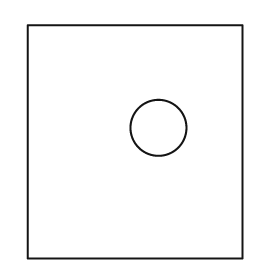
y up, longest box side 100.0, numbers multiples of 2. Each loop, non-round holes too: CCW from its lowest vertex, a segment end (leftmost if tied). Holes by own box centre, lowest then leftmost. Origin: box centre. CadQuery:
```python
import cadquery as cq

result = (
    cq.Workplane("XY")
    .moveTo(-46.0, -50.0)
    .lineTo(46.0, -50.0)
    .lineTo(46.0, 50.0)
    .lineTo(-46.0, 50.0)
    .close()
    .moveTo(10.0, 6.0)
    .circle(12.0)
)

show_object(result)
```